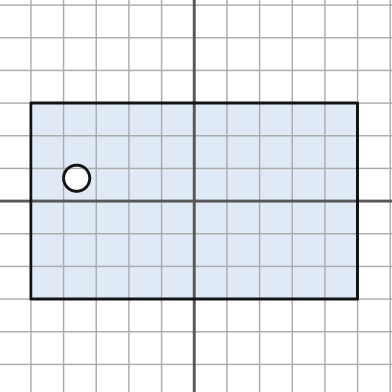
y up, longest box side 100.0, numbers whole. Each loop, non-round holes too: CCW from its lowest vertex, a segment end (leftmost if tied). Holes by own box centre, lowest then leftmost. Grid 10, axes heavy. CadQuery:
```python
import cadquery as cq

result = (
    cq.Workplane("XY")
    .moveTo(-50.0, -30.0)
    .lineTo(50.0, -30.0)
    .lineTo(50.0, 30.0)
    .lineTo(-50.0, 30.0)
    .close()
    .moveTo(-36.0, 7.0)
    .circle(4.0)
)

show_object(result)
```